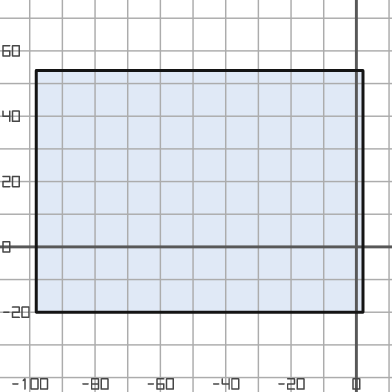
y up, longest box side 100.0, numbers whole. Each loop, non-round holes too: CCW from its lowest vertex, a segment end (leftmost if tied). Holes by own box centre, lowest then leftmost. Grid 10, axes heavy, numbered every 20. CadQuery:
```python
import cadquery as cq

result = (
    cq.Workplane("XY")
    .moveTo(-98.0, -20.0)
    .lineTo(2.0, -20.0)
    .lineTo(2.0, 54.0)
    .lineTo(-98.0, 54.0)
    .close()
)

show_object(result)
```